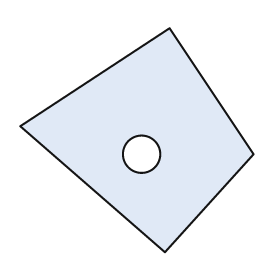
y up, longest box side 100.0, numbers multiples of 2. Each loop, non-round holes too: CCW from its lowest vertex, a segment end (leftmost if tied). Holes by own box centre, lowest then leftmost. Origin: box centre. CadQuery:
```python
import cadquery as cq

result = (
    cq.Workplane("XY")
    .moveTo(12.0, -48.0)
    .lineTo(50.0, -6.0)
    .lineTo(14.0, 48.0)
    .lineTo(-50.0, 6.0)
    .close()
    .moveTo(2.0, -6.0)
    .circle(8.0)
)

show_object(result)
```